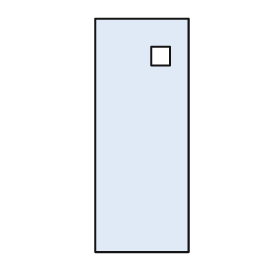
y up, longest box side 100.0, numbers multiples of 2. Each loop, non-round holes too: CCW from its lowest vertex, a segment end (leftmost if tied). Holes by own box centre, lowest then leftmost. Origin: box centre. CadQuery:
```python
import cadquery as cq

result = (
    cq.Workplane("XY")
    .moveTo(-20.0, -50.0)
    .lineTo(20.0, -50.0)
    .lineTo(20.0, 50.0)
    .lineTo(-20.0, 50.0)
    .close()
    .moveTo(4.0, 30.0)
    .lineTo(12.0, 30.0)
    .lineTo(12.0, 38.0)
    .lineTo(4.0, 38.0)
    .close()
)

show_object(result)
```